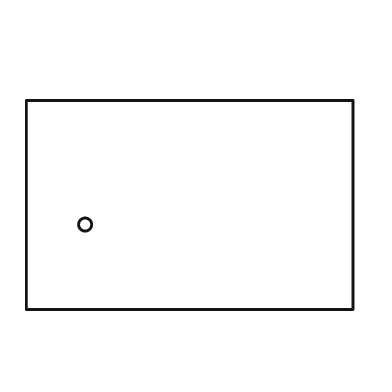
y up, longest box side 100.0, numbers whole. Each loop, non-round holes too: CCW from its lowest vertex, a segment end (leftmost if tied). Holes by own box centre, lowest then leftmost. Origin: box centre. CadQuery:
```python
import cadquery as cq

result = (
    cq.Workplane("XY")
    .moveTo(-50.0, -32.0)
    .lineTo(50.0, -32.0)
    .lineTo(50.0, 32.0)
    .lineTo(-50.0, 32.0)
    .close()
    .moveTo(-32.0, -6.0)
    .circle(2.0)
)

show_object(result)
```